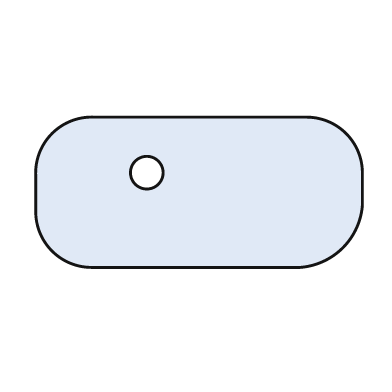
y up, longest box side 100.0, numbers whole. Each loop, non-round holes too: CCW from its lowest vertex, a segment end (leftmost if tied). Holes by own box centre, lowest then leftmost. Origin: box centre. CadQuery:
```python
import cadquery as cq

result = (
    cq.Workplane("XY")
    .moveTo(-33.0, -23.0)
    .lineTo(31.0, -23.0)
    .threePointArc((44.0, -17.0), (50.0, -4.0))
    .lineTo(50.0, 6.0)
    .threePointArc((45.0, 18.0), (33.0, 23.0))
    .lineTo(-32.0, 23.0)
    .threePointArc((-45.0, 18.0), (-50.0, 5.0))
    .lineTo(-50.0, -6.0)
    .threePointArc((-45.0, -18.0), (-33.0, -23.0))
    .close()
    .moveTo(-16.0, 6.0)
    .circle(5.0)
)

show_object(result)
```